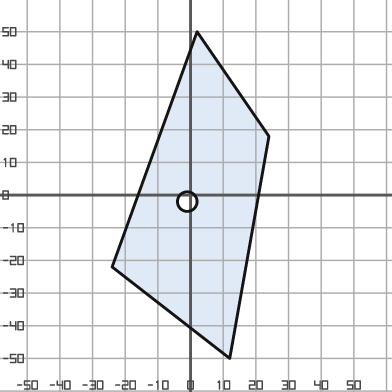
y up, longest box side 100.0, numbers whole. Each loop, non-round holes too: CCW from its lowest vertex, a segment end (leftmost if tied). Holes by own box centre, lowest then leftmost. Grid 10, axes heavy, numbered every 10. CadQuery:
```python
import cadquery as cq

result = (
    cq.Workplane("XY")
    .moveTo(12.0, -50.0)
    .lineTo(24.0, 18.0)
    .lineTo(2.0, 50.0)
    .lineTo(-24.0, -22.0)
    .close()
    .moveTo(-1.0, -2.0)
    .circle(3.0)
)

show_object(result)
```